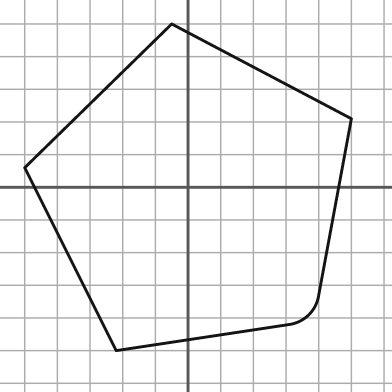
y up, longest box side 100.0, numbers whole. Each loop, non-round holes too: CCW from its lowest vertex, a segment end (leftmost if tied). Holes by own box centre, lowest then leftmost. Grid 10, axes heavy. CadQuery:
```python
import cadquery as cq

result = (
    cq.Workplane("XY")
    .moveTo(-22.0, -50.0)
    .lineTo(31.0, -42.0)
    .threePointArc((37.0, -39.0), (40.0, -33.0))
    .lineTo(50.0, 21.0)
    .lineTo(-5.0, 50.0)
    .lineTo(-50.0, 6.0)
    .close()
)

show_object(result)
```